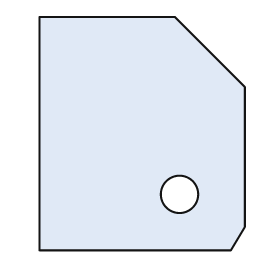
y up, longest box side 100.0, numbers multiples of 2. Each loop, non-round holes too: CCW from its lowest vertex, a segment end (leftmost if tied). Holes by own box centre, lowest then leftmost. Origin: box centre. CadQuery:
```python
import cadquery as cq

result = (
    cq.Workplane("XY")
    .moveTo(-44.0, -50.0)
    .lineTo(38.0, -50.0)
    .lineTo(44.0, -40.0)
    .lineTo(44.0, 20.0)
    .lineTo(14.0, 50.0)
    .lineTo(-44.0, 50.0)
    .close()
    .moveTo(16.0, -26.0)
    .circle(8.0)
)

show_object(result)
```